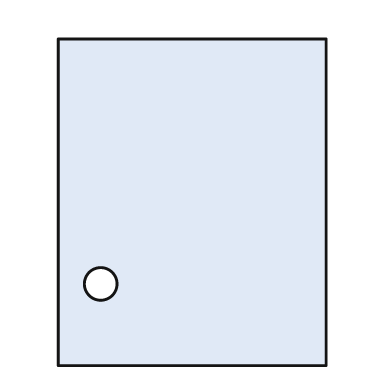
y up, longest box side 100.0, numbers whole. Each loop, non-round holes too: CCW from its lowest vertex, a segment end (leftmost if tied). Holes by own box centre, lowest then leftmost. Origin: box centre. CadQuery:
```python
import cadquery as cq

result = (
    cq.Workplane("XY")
    .moveTo(-41.0, -50.0)
    .lineTo(41.0, -50.0)
    .lineTo(41.0, 50.0)
    .lineTo(-41.0, 50.0)
    .close()
    .moveTo(-28.0, -25.0)
    .circle(5.0)
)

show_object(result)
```